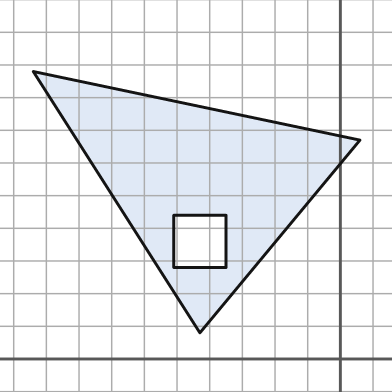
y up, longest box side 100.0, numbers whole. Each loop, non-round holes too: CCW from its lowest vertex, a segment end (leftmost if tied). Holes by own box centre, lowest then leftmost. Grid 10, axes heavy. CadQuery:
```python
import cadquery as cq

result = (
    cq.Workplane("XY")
    .moveTo(-43.0, 8.0)
    .lineTo(6.0, 67.0)
    .lineTo(-94.0, 88.0)
    .close()
    .moveTo(-51.0, 28.0)
    .lineTo(-35.0, 28.0)
    .lineTo(-35.0, 44.0)
    .lineTo(-51.0, 44.0)
    .close()
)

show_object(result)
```